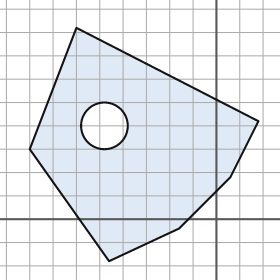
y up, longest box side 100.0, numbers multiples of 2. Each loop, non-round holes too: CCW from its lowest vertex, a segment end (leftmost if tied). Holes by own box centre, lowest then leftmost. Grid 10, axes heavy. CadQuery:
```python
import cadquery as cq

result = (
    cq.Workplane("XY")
    .moveTo(-46.0, -18.0)
    .lineTo(-16.0, -4.0)
    .lineTo(6.0, 18.0)
    .lineTo(18.0, 42.0)
    .lineTo(-60.0, 82.0)
    .lineTo(-80.0, 30.0)
    .close()
    .moveTo(-48.0, 40.0)
    .circle(10.0)
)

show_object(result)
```